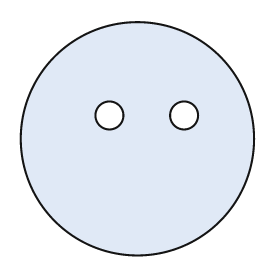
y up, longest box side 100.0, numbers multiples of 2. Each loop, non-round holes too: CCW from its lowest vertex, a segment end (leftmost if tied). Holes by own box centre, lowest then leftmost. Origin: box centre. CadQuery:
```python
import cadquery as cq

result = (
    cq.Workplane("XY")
    .moveTo(0.0, 0.0)
    .circle(50.0)
    .moveTo(-12.0, 10.0)
    .circle(6.0)
    .moveTo(20.0, 10.0)
    .circle(6.0)
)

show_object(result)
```